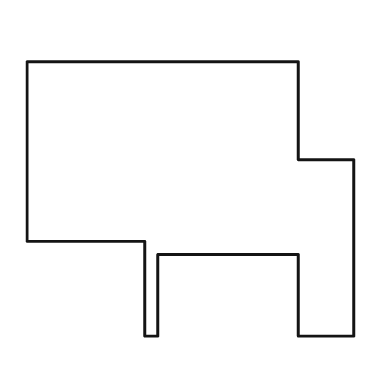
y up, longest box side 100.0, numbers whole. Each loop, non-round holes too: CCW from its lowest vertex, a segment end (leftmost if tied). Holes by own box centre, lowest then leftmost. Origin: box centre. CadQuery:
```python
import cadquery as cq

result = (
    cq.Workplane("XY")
    .moveTo(-14.0, -42.0)
    .lineTo(-10.0, -42.0)
    .lineTo(-10.0, -17.0)
    .lineTo(33.0, -17.0)
    .lineTo(33.0, -42.0)
    .lineTo(50.0, -42.0)
    .lineTo(50.0, 12.0)
    .lineTo(33.0, 12.0)
    .lineTo(33.0, 42.0)
    .lineTo(-50.0, 42.0)
    .lineTo(-50.0, -13.0)
    .lineTo(-14.0, -13.0)
    .close()
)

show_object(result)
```